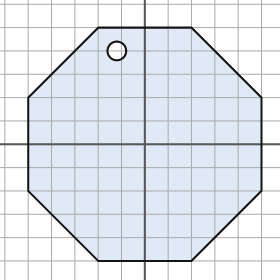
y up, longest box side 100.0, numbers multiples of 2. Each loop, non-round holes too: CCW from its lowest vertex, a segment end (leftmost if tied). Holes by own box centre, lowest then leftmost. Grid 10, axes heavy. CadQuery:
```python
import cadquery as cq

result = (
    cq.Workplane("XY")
    .moveTo(-20.0, -50.0)
    .lineTo(20.0, -50.0)
    .lineTo(50.0, -20.0)
    .lineTo(50.0, 20.0)
    .lineTo(20.0, 50.0)
    .lineTo(-20.0, 50.0)
    .lineTo(-50.0, 20.0)
    .lineTo(-50.0, -20.0)
    .close()
    .moveTo(-12.0, 40.0)
    .circle(4.0)
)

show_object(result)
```